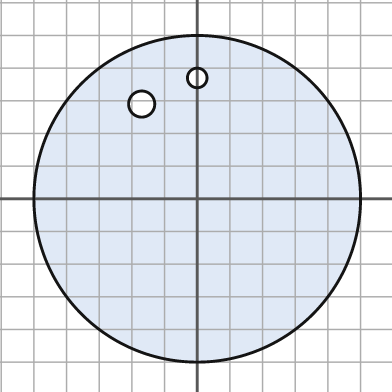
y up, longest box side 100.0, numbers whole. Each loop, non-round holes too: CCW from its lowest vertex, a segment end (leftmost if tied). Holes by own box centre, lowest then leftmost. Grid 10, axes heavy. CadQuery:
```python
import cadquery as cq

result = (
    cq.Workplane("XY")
    .moveTo(0.0, 0.0)
    .circle(50.0)
    .moveTo(-17.0, 29.0)
    .circle(4.0)
    .moveTo(0.0, 37.0)
    .circle(3.0)
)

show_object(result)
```